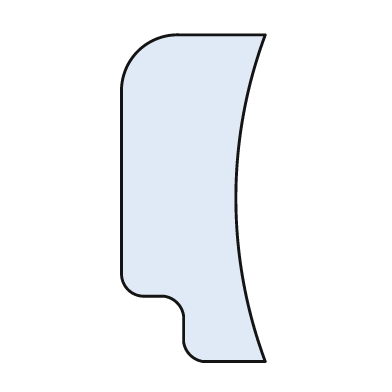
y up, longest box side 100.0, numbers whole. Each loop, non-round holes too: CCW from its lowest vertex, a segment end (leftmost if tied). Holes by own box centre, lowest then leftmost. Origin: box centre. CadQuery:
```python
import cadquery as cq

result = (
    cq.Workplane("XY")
    .moveTo(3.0, -50.0)
    .lineTo(22.0, -50.0)
    .threePointArc((13.0, 0.0), (22.0, 50.0))
    .lineTo(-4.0, 50.0)
    .threePointArc((-17.0, 45.0), (-22.0, 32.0))
    .lineTo(-22.0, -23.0)
    .threePointArc((-20.0, -28.0), (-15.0, -30.0))
    .lineTo(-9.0, -30.0)
    .threePointArc((-5.0, -32.0), (-3.0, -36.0))
    .lineTo(-3.0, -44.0)
    .threePointArc((-1.0, -48.0), (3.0, -50.0))
    .close()
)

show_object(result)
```